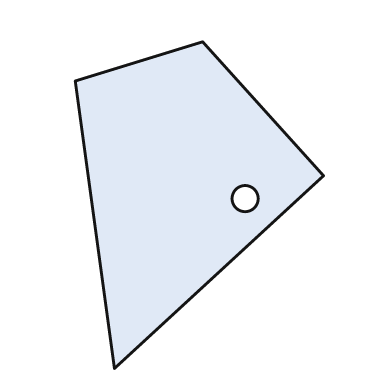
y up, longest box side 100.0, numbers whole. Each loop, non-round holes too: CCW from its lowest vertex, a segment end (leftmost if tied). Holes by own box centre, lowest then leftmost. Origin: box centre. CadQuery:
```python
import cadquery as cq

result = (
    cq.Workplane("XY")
    .moveTo(-26.0, -50.0)
    .lineTo(38.0, 9.0)
    .lineTo(1.0, 50.0)
    .lineTo(-38.0, 38.0)
    .close()
    .moveTo(14.0, 2.0)
    .circle(4.0)
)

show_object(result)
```